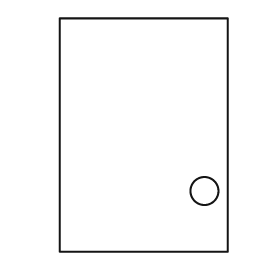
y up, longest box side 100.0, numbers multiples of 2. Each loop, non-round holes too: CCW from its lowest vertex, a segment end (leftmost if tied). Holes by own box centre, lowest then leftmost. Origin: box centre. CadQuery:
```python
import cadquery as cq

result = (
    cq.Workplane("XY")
    .moveTo(-36.0, -50.0)
    .lineTo(36.0, -50.0)
    .lineTo(36.0, 50.0)
    .lineTo(-36.0, 50.0)
    .close()
    .moveTo(26.0, -24.0)
    .circle(6.0)
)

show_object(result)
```